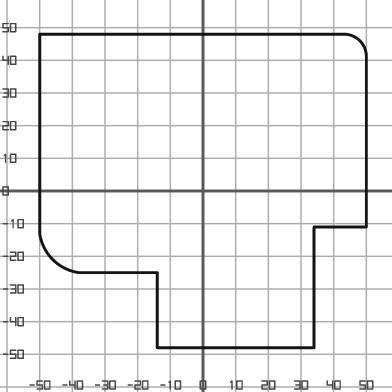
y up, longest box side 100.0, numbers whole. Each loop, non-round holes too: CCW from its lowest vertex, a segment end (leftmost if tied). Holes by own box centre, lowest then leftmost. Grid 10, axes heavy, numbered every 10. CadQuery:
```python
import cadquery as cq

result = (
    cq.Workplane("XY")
    .moveTo(-14.0, -48.0)
    .lineTo(34.0, -48.0)
    .lineTo(34.0, -11.0)
    .lineTo(50.0, -11.0)
    .lineTo(50.0, 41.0)
    .threePointArc((48.0, 46.0), (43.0, 48.0))
    .lineTo(-50.0, 48.0)
    .lineTo(-50.0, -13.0)
    .threePointArc((-46.0, -21.0), (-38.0, -25.0))
    .lineTo(-14.0, -25.0)
    .close()
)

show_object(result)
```